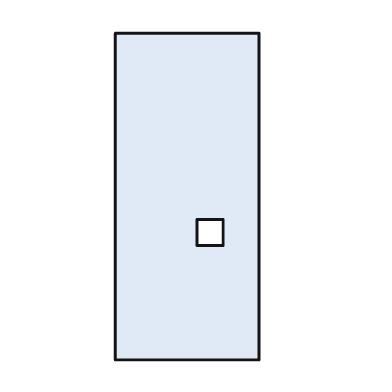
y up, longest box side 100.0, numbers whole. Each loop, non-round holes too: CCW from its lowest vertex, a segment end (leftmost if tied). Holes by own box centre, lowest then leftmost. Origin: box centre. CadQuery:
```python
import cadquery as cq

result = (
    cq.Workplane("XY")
    .moveTo(-22.0, -50.0)
    .lineTo(22.0, -50.0)
    .lineTo(22.0, 50.0)
    .lineTo(-22.0, 50.0)
    .close()
    .moveTo(3.0, -15.0)
    .lineTo(11.0, -15.0)
    .lineTo(11.0, -7.0)
    .lineTo(3.0, -7.0)
    .close()
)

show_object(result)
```